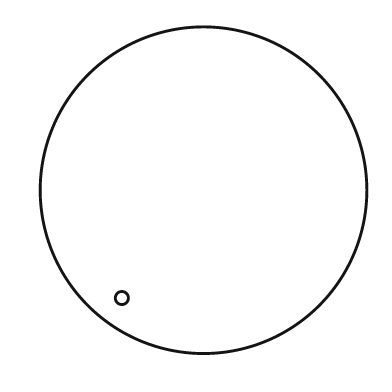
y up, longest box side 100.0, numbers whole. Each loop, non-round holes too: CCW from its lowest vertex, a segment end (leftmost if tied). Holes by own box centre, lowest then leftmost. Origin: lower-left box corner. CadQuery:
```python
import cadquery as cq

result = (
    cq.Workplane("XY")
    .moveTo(50.0, 50.0)
    .circle(50.0)
    .moveTo(25.0, 17.0)
    .circle(2.0)
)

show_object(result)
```